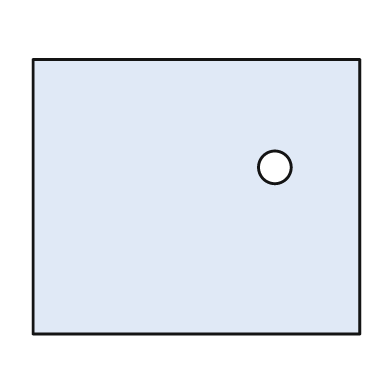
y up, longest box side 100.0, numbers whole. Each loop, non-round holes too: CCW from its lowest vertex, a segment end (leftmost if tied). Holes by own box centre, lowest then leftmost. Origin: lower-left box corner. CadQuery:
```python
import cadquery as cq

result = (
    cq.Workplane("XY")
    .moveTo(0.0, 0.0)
    .lineTo(100.0, 0.0)
    .lineTo(100.0, 84.0)
    .lineTo(0.0, 84.0)
    .close()
    .moveTo(74.0, 51.0)
    .circle(5.0)
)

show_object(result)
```